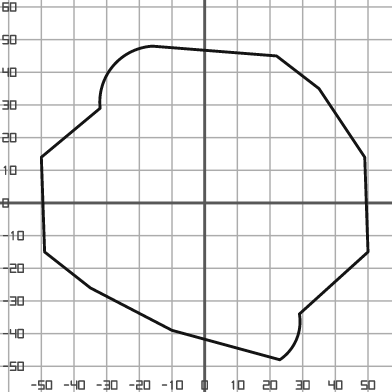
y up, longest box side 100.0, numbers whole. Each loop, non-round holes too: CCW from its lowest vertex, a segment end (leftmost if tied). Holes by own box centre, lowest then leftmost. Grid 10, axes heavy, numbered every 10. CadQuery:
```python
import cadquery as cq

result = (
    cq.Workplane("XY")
    .moveTo(23.0, -48.0)
    .threePointArc((28.0, -42.0), (29.0, -34.0))
    .lineTo(50.0, -15.0)
    .lineTo(49.0, 14.0)
    .lineTo(35.0, 35.0)
    .lineTo(22.0, 45.0)
    .lineTo(-16.0, 48.0)
    .threePointArc((-28.0, 42.0), (-32.0, 29.0))
    .lineTo(-50.0, 14.0)
    .lineTo(-49.0, -15.0)
    .lineTo(-35.0, -26.0)
    .lineTo(-10.0, -39.0)
    .close()
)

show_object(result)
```